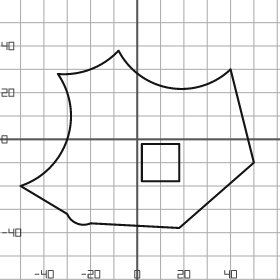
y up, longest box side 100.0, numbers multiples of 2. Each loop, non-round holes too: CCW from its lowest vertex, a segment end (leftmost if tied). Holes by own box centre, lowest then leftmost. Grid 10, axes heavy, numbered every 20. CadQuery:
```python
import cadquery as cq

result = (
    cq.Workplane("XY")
    .moveTo(18.0, -38.0)
    .lineTo(50.0, -10.0)
    .lineTo(40.0, 30.0)
    .threePointArc((14.0, 22.0), (-8.0, 38.0))
    .threePointArc((-20.0, 30.0), (-34.0, 28.0))
    .threePointArc((-30.0, 0.0), (-50.0, -20.0))
    .lineTo(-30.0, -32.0)
    .threePointArc((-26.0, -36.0), (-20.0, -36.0))
    .close()
    .moveTo(2.0, -18.0)
    .lineTo(18.0, -18.0)
    .lineTo(18.0, -2.0)
    .lineTo(2.0, -2.0)
    .close()
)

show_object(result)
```